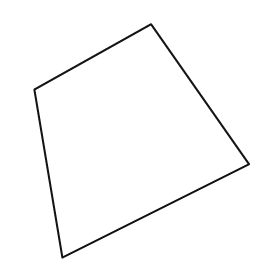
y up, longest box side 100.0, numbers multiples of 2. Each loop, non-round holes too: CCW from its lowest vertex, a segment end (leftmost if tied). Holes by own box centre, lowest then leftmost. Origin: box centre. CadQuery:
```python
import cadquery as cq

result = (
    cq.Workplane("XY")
    .moveTo(-34.0, -50.0)
    .lineTo(46.0, -10.0)
    .lineTo(4.0, 50.0)
    .lineTo(-46.0, 22.0)
    .close()
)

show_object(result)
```